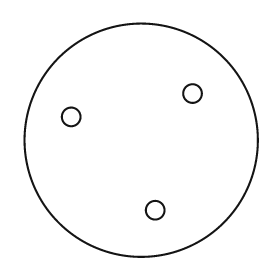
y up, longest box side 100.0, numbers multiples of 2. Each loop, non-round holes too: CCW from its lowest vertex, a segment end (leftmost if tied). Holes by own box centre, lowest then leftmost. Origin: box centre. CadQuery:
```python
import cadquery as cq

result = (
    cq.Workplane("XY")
    .moveTo(0.0, 0.0)
    .circle(50.0)
    .moveTo(6.0, -30.0)
    .circle(4.0)
    .moveTo(-30.0, 10.0)
    .circle(4.0)
    .moveTo(22.0, 20.0)
    .circle(4.0)
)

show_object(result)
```